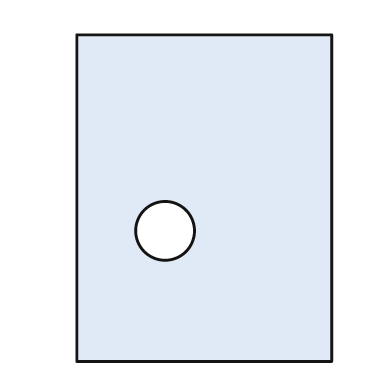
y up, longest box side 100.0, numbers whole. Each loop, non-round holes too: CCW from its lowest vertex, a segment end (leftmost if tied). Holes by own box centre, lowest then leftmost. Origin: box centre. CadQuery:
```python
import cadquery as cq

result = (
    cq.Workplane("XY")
    .moveTo(-39.0, -50.0)
    .lineTo(39.0, -50.0)
    .lineTo(39.0, 50.0)
    .lineTo(-39.0, 50.0)
    .close()
    .moveTo(-12.0, -10.0)
    .circle(9.0)
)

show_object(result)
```